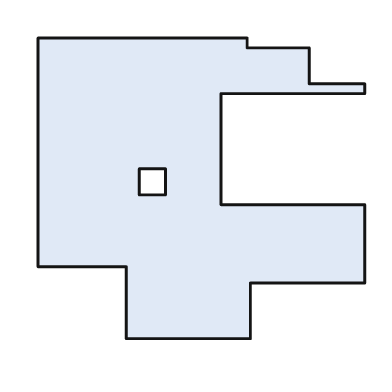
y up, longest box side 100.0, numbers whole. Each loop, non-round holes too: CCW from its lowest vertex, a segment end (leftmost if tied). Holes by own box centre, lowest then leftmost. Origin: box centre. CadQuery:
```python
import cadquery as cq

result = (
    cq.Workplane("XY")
    .moveTo(-23.0, -46.0)
    .lineTo(15.0, -46.0)
    .lineTo(15.0, -29.0)
    .lineTo(50.0, -29.0)
    .lineTo(50.0, -5.0)
    .lineTo(6.0, -5.0)
    .lineTo(6.0, 29.0)
    .lineTo(50.0, 29.0)
    .lineTo(50.0, 32.0)
    .lineTo(33.0, 32.0)
    .lineTo(33.0, 43.0)
    .lineTo(14.0, 43.0)
    .lineTo(14.0, 46.0)
    .lineTo(-50.0, 46.0)
    .lineTo(-50.0, -24.0)
    .lineTo(-23.0, -24.0)
    .close()
    .moveTo(-19.0, -2.0)
    .lineTo(-11.0, -2.0)
    .lineTo(-11.0, 6.0)
    .lineTo(-19.0, 6.0)
    .close()
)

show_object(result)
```